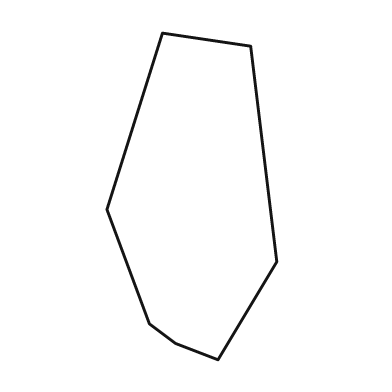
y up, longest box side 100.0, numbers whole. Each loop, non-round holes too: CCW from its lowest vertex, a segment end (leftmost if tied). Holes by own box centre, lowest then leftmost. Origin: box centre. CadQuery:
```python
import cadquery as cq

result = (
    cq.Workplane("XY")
    .moveTo(8.0, -50.0)
    .lineTo(26.0, -20.0)
    .lineTo(18.0, 46.0)
    .lineTo(-9.0, 50.0)
    .lineTo(-26.0, -4.0)
    .lineTo(-13.0, -39.0)
    .lineTo(-5.0, -45.0)
    .close()
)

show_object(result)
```